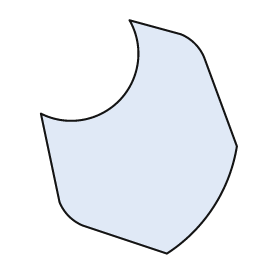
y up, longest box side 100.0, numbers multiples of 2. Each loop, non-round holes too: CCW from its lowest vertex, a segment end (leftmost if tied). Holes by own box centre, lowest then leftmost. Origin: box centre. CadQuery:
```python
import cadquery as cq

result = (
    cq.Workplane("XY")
    .moveTo(12.0, -50.0)
    .threePointArc((32.0, -30.0), (42.0, -4.0))
    .lineTo(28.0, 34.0)
    .threePointArc((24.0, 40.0), (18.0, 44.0))
    .lineTo(-4.0, 50.0)
    .threePointArc((-8.0, 16.0), (-42.0, 10.0))
    .lineTo(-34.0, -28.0)
    .threePointArc((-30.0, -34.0), (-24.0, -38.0))
    .close()
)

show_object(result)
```